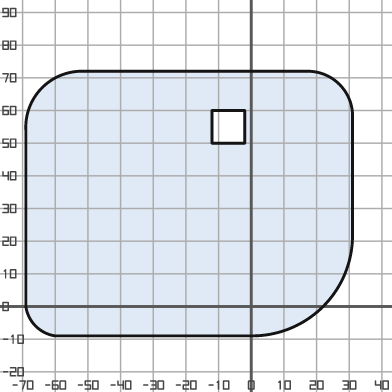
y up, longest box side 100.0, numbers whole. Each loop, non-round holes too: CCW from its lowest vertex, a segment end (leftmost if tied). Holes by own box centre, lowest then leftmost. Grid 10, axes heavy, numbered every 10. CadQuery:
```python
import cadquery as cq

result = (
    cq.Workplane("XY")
    .moveTo(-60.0, -9.0)
    .lineTo(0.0, -9.0)
    .threePointArc((22.0, 0.0), (31.0, 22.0))
    .lineTo(31.0, 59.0)
    .threePointArc((27.0, 68.0), (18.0, 72.0))
    .lineTo(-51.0, 72.0)
    .threePointArc((-64.0, 67.0), (-69.0, 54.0))
    .lineTo(-69.0, 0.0)
    .threePointArc((-66.0, -6.0), (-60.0, -9.0))
    .close()
    .moveTo(-12.0, 50.0)
    .lineTo(-2.0, 50.0)
    .lineTo(-2.0, 60.0)
    .lineTo(-12.0, 60.0)
    .close()
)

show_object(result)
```